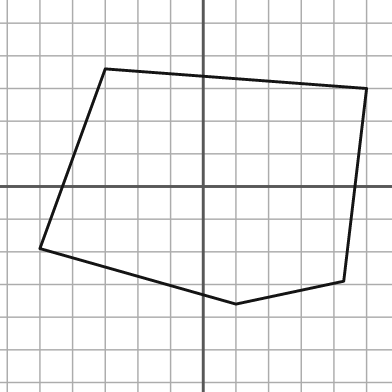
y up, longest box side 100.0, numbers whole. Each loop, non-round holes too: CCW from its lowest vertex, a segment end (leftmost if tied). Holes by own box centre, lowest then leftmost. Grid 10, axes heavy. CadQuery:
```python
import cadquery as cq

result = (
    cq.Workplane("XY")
    .moveTo(10.0, -36.0)
    .lineTo(43.0, -29.0)
    .lineTo(50.0, 30.0)
    .lineTo(-30.0, 36.0)
    .lineTo(-50.0, -19.0)
    .close()
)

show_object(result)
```